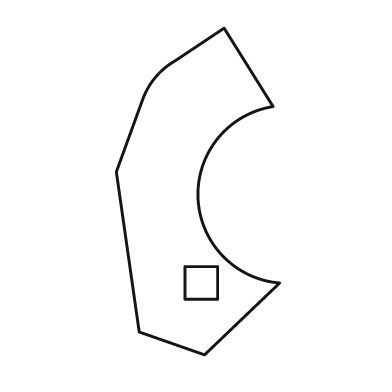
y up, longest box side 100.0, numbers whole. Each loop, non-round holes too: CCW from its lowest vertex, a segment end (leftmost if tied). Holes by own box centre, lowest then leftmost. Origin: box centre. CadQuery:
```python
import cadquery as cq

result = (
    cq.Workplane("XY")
    .moveTo(2.0, -50.0)
    .lineTo(25.0, -28.0)
    .threePointArc((0.0, -2.0), (23.0, 26.0))
    .lineTo(8.0, 50.0)
    .lineTo(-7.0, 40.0)
    .threePointArc((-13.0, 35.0), (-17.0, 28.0))
    .lineTo(-25.0, 6.0)
    .lineTo(-18.0, -43.0)
    .close()
    .moveTo(-4.0, -33.0)
    .lineTo(6.0, -33.0)
    .lineTo(6.0, -23.0)
    .lineTo(-4.0, -23.0)
    .close()
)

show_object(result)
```